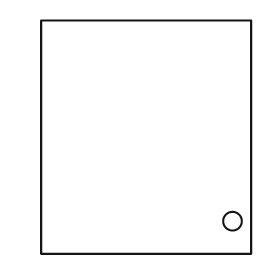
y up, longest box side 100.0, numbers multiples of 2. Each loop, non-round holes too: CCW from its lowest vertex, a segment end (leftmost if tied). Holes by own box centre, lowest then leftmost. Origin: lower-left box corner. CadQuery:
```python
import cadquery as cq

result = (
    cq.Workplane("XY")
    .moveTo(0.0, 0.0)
    .lineTo(90.0, 0.0)
    .lineTo(90.0, 100.0)
    .lineTo(0.0, 100.0)
    .close()
    .moveTo(82.0, 14.0)
    .circle(4.0)
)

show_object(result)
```